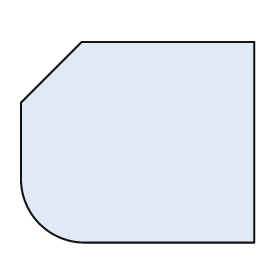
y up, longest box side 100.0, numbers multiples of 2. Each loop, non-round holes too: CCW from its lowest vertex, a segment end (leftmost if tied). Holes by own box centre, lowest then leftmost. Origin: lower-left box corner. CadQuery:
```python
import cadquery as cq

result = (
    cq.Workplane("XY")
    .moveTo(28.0, 0.0)
    .lineTo(100.0, 0.0)
    .lineTo(100.0, 86.0)
    .lineTo(26.0, 86.0)
    .lineTo(0.0, 60.0)
    .lineTo(0.0, 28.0)
    .threePointArc((8.0, 8.0), (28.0, 0.0))
    .close()
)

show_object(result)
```